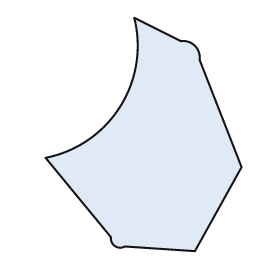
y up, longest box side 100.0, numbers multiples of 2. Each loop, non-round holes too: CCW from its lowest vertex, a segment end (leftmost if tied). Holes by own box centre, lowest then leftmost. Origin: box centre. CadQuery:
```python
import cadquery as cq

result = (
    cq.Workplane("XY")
    .moveTo(22.0, -50.0)
    .lineTo(42.0, -14.0)
    .lineTo(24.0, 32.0)
    .threePointArc((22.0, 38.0), (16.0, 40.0))
    .lineTo(-4.0, 50.0)
    .threePointArc((-10.0, 12.0), (-42.0, -10.0))
    .lineTo(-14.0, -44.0)
    .threePointArc((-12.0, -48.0), (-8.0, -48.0))
    .close()
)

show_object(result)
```